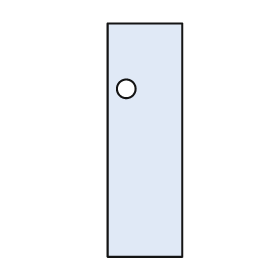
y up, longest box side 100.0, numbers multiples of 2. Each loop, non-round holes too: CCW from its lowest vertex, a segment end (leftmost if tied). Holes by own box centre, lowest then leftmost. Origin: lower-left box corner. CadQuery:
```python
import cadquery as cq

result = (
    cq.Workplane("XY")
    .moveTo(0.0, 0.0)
    .lineTo(32.0, 0.0)
    .lineTo(32.0, 100.0)
    .lineTo(0.0, 100.0)
    .close()
    .moveTo(8.0, 72.0)
    .circle(4.0)
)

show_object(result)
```